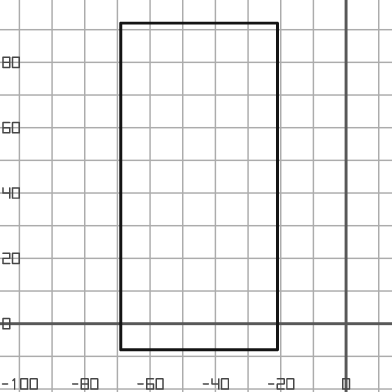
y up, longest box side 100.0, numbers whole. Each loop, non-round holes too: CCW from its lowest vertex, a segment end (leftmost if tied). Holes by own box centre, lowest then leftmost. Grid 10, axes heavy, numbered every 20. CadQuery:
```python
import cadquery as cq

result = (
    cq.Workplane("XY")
    .moveTo(-69.0, -8.0)
    .lineTo(-21.0, -8.0)
    .lineTo(-21.0, 92.0)
    .lineTo(-69.0, 92.0)
    .close()
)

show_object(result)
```